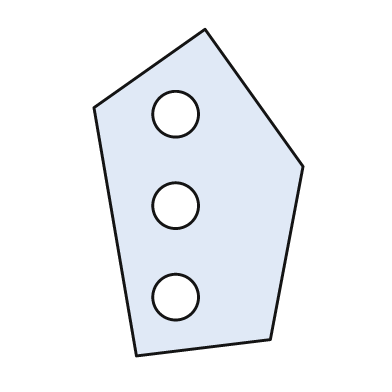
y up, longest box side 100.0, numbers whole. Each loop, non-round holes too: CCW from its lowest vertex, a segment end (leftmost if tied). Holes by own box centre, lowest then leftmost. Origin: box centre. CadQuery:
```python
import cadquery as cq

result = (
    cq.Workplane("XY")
    .moveTo(-19.0, -50.0)
    .lineTo(22.0, -45.0)
    .lineTo(32.0, 8.0)
    .lineTo(2.0, 50.0)
    .lineTo(-32.0, 26.0)
    .close()
    .moveTo(-7.0, -32.0)
    .circle(7.0)
    .moveTo(-7.0, -4.0)
    .circle(7.0)
    .moveTo(-7.0, 24.0)
    .circle(7.0)
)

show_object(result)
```